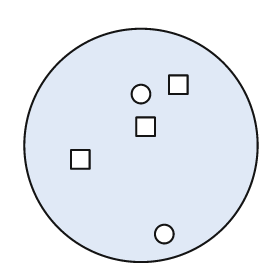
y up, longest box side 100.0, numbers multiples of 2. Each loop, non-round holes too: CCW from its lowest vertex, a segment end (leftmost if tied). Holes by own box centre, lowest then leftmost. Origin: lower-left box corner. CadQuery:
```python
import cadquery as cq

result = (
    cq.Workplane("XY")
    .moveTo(50.0, 50.0)
    .circle(50.0)
    .moveTo(60.0, 12.0)
    .circle(4.0)
    .moveTo(20.0, 40.0)
    .lineTo(28.0, 40.0)
    .lineTo(28.0, 48.0)
    .lineTo(20.0, 48.0)
    .close()
    .moveTo(48.0, 54.0)
    .lineTo(56.0, 54.0)
    .lineTo(56.0, 62.0)
    .lineTo(48.0, 62.0)
    .close()
    .moveTo(50.0, 72.0)
    .circle(4.0)
    .moveTo(62.0, 72.0)
    .lineTo(70.0, 72.0)
    .lineTo(70.0, 80.0)
    .lineTo(62.0, 80.0)
    .close()
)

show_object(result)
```